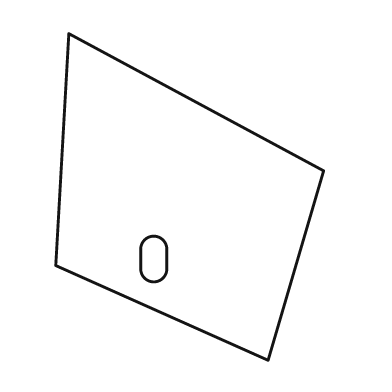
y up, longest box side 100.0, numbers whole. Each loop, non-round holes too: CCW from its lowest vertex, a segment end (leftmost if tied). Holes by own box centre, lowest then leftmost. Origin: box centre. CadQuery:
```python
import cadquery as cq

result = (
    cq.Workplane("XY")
    .moveTo(24.0, -50.0)
    .lineTo(41.0, 8.0)
    .lineTo(-37.0, 50.0)
    .lineTo(-41.0, -21.0)
    .close()
    .moveTo(-15.0, -22.0)
    .threePointArc((-11.0, -26.0), (-7.0, -22.0))
    .lineTo(-7.0, -16.0)
    .threePointArc((-11.0, -12.0), (-15.0, -16.0))
    .close()
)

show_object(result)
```